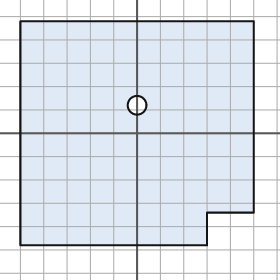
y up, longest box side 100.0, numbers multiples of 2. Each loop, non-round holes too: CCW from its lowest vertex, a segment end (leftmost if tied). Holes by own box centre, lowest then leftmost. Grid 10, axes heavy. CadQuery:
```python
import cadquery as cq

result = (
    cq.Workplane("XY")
    .moveTo(-50.0, -48.0)
    .lineTo(30.0, -48.0)
    .lineTo(30.0, -34.0)
    .lineTo(50.0, -34.0)
    .lineTo(50.0, 48.0)
    .lineTo(-50.0, 48.0)
    .close()
    .moveTo(0.0, 12.0)
    .circle(4.0)
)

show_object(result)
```